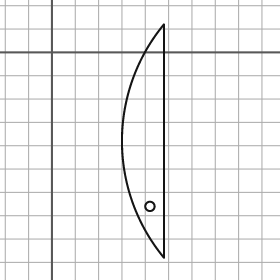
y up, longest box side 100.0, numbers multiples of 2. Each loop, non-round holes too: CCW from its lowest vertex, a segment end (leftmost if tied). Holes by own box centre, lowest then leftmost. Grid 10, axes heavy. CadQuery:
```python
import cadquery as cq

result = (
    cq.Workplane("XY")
    .moveTo(48.0, -88.0)
    .lineTo(48.0, 12.0)
    .threePointArc((30.0, -38.0), (48.0, -88.0))
    .close()
    .moveTo(42.0, -66.0)
    .circle(2.0)
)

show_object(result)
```